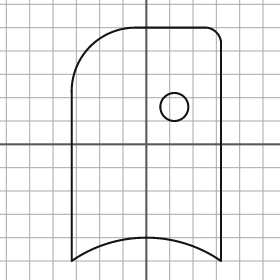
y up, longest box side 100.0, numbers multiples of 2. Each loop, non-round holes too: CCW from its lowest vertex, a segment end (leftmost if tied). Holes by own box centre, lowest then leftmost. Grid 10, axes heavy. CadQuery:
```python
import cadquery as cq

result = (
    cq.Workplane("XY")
    .moveTo(-32.0, -50.0)
    .threePointArc((0.0, -40.0), (32.0, -50.0))
    .lineTo(32.0, 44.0)
    .threePointArc((30.0, 48.0), (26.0, 50.0))
    .lineTo(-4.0, 50.0)
    .threePointArc((-24.0, 42.0), (-32.0, 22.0))
    .close()
    .moveTo(12.0, 16.0)
    .circle(6.0)
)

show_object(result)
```